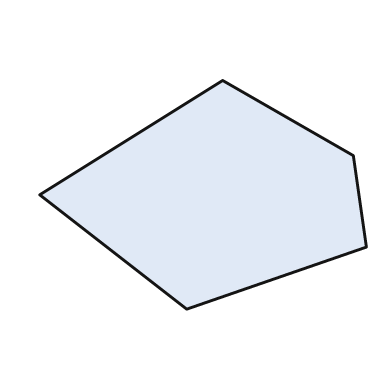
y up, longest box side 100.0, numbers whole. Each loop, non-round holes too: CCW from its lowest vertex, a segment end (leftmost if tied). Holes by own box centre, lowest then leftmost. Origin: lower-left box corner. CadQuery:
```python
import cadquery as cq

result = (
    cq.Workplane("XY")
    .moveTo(45.0, 0.0)
    .lineTo(100.0, 19.0)
    .lineTo(96.0, 47.0)
    .lineTo(56.0, 70.0)
    .lineTo(0.0, 35.0)
    .close()
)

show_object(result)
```